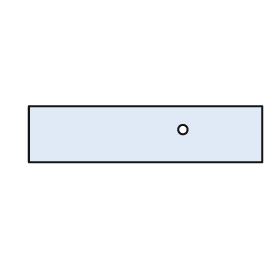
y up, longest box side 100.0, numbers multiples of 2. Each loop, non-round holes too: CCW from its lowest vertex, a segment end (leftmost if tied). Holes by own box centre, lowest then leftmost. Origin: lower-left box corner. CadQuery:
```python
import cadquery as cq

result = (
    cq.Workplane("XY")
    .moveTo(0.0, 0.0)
    .lineTo(100.0, 0.0)
    .lineTo(100.0, 24.0)
    .lineTo(0.0, 24.0)
    .close()
    .moveTo(66.0, 14.0)
    .circle(2.0)
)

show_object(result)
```